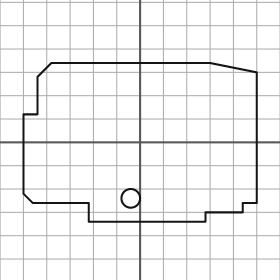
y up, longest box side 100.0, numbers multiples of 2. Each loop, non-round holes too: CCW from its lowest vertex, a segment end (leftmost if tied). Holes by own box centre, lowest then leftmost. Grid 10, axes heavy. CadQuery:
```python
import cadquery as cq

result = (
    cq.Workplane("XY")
    .moveTo(-22.0, -34.0)
    .lineTo(28.0, -34.0)
    .lineTo(28.0, -30.0)
    .lineTo(44.0, -30.0)
    .lineTo(44.0, -26.0)
    .lineTo(50.0, -26.0)
    .lineTo(50.0, 30.0)
    .lineTo(30.0, 34.0)
    .lineTo(-38.0, 34.0)
    .lineTo(-44.0, 28.0)
    .lineTo(-44.0, 12.0)
    .lineTo(-50.0, 12.0)
    .lineTo(-50.0, -22.0)
    .lineTo(-46.0, -26.0)
    .lineTo(-22.0, -26.0)
    .close()
    .moveTo(-4.0, -24.0)
    .circle(4.0)
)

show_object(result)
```